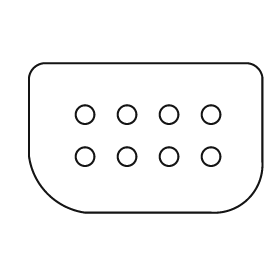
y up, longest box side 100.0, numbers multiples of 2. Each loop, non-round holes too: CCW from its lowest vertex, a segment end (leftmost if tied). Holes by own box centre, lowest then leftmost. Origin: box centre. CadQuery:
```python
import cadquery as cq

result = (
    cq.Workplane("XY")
    .moveTo(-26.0, -32.0)
    .lineTo(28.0, -32.0)
    .threePointArc((44.0, -26.0), (50.0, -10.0))
    .lineTo(50.0, 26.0)
    .threePointArc((48.0, 30.0), (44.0, 32.0))
    .lineTo(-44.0, 32.0)
    .threePointArc((-48.0, 30.0), (-50.0, 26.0))
    .lineTo(-50.0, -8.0)
    .threePointArc((-42.0, -24.0), (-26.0, -32.0))
    .close()
    .moveTo(-26.0, -8.0)
    .circle(4.0)
    .moveTo(-8.0, -8.0)
    .circle(4.0)
    .moveTo(10.0, -8.0)
    .circle(4.0)
    .moveTo(28.0, -8.0)
    .circle(4.0)
    .moveTo(-26.0, 10.0)
    .circle(4.0)
    .moveTo(-8.0, 10.0)
    .circle(4.0)
    .moveTo(10.0, 10.0)
    .circle(4.0)
    .moveTo(28.0, 10.0)
    .circle(4.0)
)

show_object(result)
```